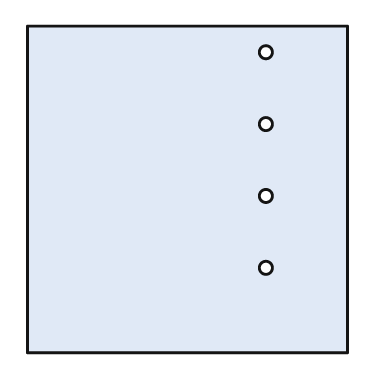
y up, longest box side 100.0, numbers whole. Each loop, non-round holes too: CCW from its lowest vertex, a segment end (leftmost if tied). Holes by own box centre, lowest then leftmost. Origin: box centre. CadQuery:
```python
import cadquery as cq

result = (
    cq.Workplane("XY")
    .moveTo(-49.0, -50.0)
    .lineTo(49.0, -50.0)
    .lineTo(49.0, 50.0)
    .lineTo(-49.0, 50.0)
    .close()
    .moveTo(24.0, -24.0)
    .circle(2.0)
    .moveTo(24.0, -2.0)
    .circle(2.0)
    .moveTo(24.0, 20.0)
    .circle(2.0)
    .moveTo(24.0, 42.0)
    .circle(2.0)
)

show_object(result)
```